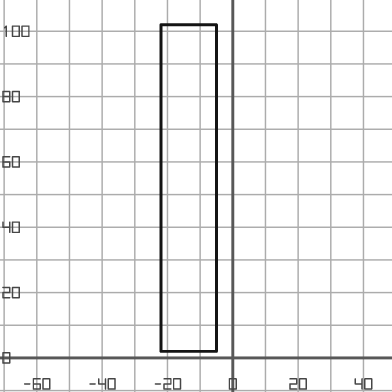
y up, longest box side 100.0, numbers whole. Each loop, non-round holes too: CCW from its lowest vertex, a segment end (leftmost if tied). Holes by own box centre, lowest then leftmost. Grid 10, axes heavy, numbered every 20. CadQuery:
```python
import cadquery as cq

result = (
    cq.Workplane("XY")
    .moveTo(-22.0, 2.0)
    .lineTo(-5.0, 2.0)
    .lineTo(-5.0, 102.0)
    .lineTo(-22.0, 102.0)
    .close()
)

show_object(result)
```